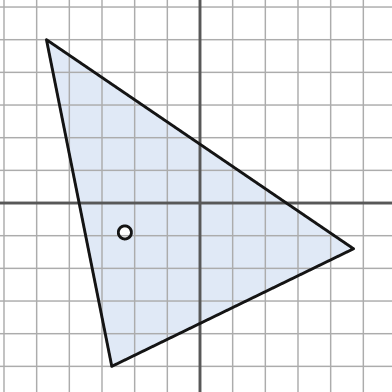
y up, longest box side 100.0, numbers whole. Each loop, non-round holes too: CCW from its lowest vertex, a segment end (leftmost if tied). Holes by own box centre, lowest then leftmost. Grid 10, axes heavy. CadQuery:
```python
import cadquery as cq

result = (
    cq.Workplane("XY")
    .moveTo(-27.0, -50.0)
    .lineTo(47.0, -14.0)
    .lineTo(-47.0, 50.0)
    .close()
    .moveTo(-23.0, -9.0)
    .circle(2.0)
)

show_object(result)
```